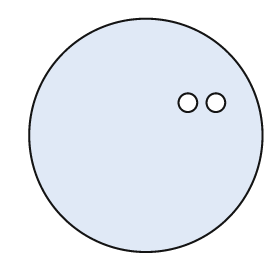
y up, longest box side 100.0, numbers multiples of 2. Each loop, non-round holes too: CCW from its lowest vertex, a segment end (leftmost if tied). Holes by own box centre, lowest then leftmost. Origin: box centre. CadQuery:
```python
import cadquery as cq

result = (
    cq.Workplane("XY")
    .moveTo(0.0, 0.0)
    .circle(50.0)
    .moveTo(18.0, 14.0)
    .circle(4.0)
    .moveTo(30.0, 14.0)
    .circle(4.0)
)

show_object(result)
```